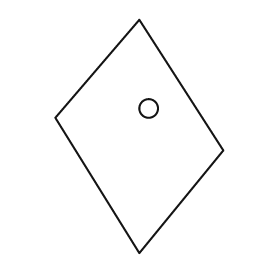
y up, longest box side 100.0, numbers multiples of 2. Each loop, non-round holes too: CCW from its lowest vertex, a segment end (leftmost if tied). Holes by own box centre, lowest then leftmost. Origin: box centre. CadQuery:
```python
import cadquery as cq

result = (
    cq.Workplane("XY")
    .moveTo(0.0, -50.0)
    .lineTo(36.0, -6.0)
    .lineTo(0.0, 50.0)
    .lineTo(-36.0, 8.0)
    .close()
    .moveTo(4.0, 12.0)
    .circle(4.0)
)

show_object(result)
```